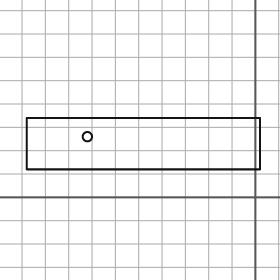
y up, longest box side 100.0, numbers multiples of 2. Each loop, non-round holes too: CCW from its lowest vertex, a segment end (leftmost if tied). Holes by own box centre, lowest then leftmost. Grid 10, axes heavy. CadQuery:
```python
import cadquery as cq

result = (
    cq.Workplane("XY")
    .moveTo(-98.0, 12.0)
    .lineTo(2.0, 12.0)
    .lineTo(2.0, 34.0)
    .lineTo(-98.0, 34.0)
    .close()
    .moveTo(-72.0, 26.0)
    .circle(2.0)
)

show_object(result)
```